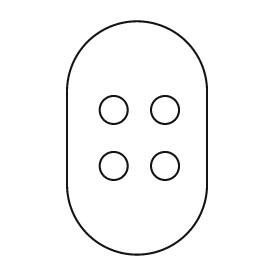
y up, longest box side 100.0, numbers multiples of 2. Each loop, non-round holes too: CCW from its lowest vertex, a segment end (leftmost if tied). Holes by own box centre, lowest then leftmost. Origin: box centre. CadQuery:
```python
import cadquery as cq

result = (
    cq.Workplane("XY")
    .moveTo(-30.0, -20.0)
    .threePointArc((0.0, -50.0), (30.0, -20.0))
    .lineTo(30.0, 20.0)
    .threePointArc((0.0, 50.0), (-30.0, 20.0))
    .close()
    .moveTo(-10.0, -12.0)
    .circle(6.0)
    .moveTo(12.0, -12.0)
    .circle(6.0)
    .moveTo(-10.0, 12.0)
    .circle(6.0)
    .moveTo(12.0, 12.0)
    .circle(6.0)
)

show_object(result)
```